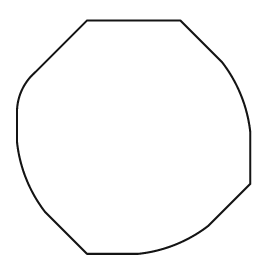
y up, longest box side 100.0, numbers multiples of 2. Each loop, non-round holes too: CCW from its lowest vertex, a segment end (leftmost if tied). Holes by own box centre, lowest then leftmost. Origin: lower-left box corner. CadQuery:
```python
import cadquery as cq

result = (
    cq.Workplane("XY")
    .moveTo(30.0, 0.0)
    .lineTo(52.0, 0.0)
    .threePointArc((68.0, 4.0), (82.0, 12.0))
    .lineTo(100.0, 30.0)
    .lineTo(100.0, 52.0)
    .threePointArc((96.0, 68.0), (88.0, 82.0))
    .lineTo(70.0, 100.0)
    .lineTo(30.0, 100.0)
    .lineTo(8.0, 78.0)
    .threePointArc((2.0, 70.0), (0.0, 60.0))
    .lineTo(0.0, 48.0)
    .threePointArc((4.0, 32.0), (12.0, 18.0))
    .close()
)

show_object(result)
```